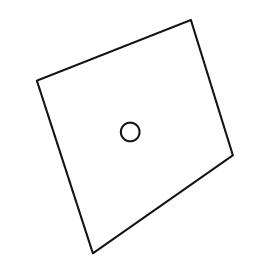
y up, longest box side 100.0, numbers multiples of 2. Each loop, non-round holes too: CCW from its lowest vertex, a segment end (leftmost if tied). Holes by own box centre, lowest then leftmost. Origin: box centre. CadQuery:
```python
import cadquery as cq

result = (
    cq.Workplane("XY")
    .moveTo(-18.0, -50.0)
    .lineTo(42.0, -8.0)
    .lineTo(24.0, 50.0)
    .lineTo(-42.0, 24.0)
    .close()
    .moveTo(-2.0, 2.0)
    .circle(4.0)
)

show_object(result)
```